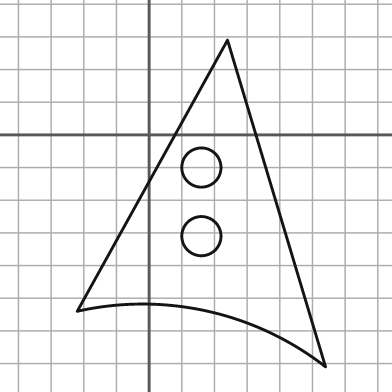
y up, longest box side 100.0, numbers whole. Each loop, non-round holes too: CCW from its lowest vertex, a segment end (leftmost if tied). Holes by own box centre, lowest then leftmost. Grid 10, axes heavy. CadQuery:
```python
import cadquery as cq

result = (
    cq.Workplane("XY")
    .moveTo(54.0, -71.0)
    .lineTo(24.0, 29.0)
    .lineTo(-22.0, -54.0)
    .threePointArc((18.0, -54.0), (54.0, -71.0))
    .close()
    .moveTo(16.0, -31.0)
    .circle(6.0)
    .moveTo(16.0, -10.0)
    .circle(6.0)
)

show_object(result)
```